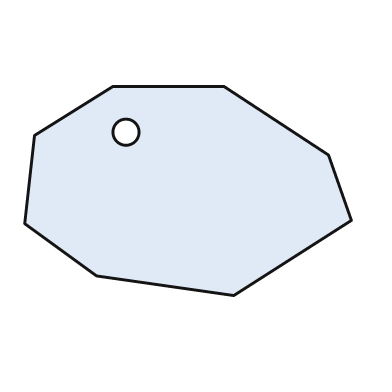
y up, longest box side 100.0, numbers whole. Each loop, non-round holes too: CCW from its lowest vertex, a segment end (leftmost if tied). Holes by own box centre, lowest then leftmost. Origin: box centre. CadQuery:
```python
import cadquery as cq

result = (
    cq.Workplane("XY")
    .moveTo(14.0, -32.0)
    .lineTo(50.0, -9.0)
    .lineTo(43.0, 11.0)
    .lineTo(11.0, 32.0)
    .lineTo(-23.0, 32.0)
    .lineTo(-47.0, 17.0)
    .lineTo(-50.0, -10.0)
    .lineTo(-28.0, -26.0)
    .close()
    .moveTo(-19.0, 18.0)
    .circle(4.0)
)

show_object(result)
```